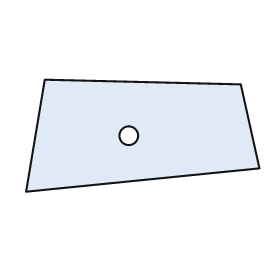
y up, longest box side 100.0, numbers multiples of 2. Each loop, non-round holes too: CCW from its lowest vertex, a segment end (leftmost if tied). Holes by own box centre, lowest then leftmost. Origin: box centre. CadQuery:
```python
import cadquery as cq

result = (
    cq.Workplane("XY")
    .moveTo(-50.0, -24.0)
    .lineTo(50.0, -14.0)
    .lineTo(42.0, 22.0)
    .lineTo(-42.0, 24.0)
    .close()
    .moveTo(-6.0, 0.0)
    .circle(4.0)
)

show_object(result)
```